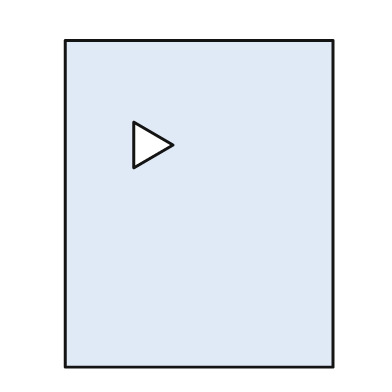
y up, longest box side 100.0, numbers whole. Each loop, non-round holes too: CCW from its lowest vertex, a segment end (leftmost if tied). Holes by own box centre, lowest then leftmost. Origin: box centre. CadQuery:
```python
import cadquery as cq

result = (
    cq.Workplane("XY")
    .moveTo(-41.0, -50.0)
    .lineTo(41.0, -50.0)
    .lineTo(41.0, 50.0)
    .lineTo(-41.0, 50.0)
    .close()
    .moveTo(-20.0, 11.0)
    .lineTo(-8.0, 18.0)
    .lineTo(-20.0, 25.0)
    .close()
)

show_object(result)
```